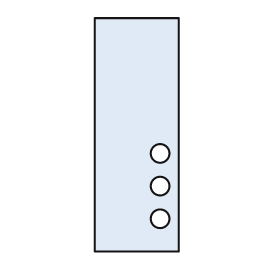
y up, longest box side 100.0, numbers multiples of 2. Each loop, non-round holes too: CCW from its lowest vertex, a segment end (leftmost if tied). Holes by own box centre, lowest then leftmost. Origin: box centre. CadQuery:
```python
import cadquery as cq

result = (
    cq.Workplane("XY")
    .moveTo(-18.0, -50.0)
    .lineTo(18.0, -50.0)
    .lineTo(18.0, 50.0)
    .lineTo(-18.0, 50.0)
    .close()
    .moveTo(10.0, -36.0)
    .circle(4.0)
    .moveTo(10.0, -22.0)
    .circle(4.0)
    .moveTo(10.0, -8.0)
    .circle(4.0)
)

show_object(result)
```